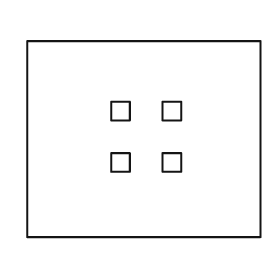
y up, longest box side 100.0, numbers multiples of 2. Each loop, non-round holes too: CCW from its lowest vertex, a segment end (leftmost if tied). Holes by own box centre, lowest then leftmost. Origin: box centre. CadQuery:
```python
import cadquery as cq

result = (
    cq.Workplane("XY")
    .moveTo(-50.0, -42.0)
    .lineTo(50.0, -42.0)
    .lineTo(50.0, 42.0)
    .lineTo(-50.0, 42.0)
    .close()
    .moveTo(-14.0, -14.0)
    .lineTo(-6.0, -14.0)
    .lineTo(-6.0, -6.0)
    .lineTo(-14.0, -6.0)
    .close()
    .moveTo(8.0, -14.0)
    .lineTo(16.0, -14.0)
    .lineTo(16.0, -6.0)
    .lineTo(8.0, -6.0)
    .close()
    .moveTo(-14.0, 8.0)
    .lineTo(-6.0, 8.0)
    .lineTo(-6.0, 16.0)
    .lineTo(-14.0, 16.0)
    .close()
    .moveTo(8.0, 8.0)
    .lineTo(16.0, 8.0)
    .lineTo(16.0, 16.0)
    .lineTo(8.0, 16.0)
    .close()
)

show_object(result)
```